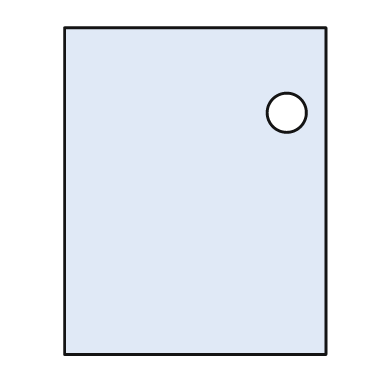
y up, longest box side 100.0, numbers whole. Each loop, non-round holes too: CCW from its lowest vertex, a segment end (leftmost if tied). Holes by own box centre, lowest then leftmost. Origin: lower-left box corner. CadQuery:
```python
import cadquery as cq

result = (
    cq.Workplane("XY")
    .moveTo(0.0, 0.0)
    .lineTo(80.0, 0.0)
    .lineTo(80.0, 100.0)
    .lineTo(0.0, 100.0)
    .close()
    .moveTo(68.0, 74.0)
    .circle(6.0)
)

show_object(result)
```